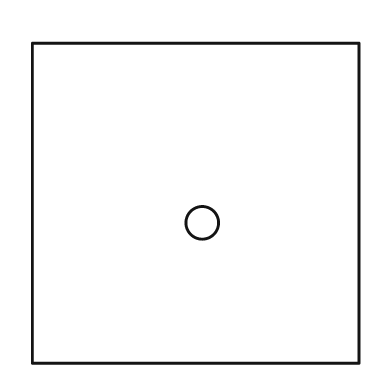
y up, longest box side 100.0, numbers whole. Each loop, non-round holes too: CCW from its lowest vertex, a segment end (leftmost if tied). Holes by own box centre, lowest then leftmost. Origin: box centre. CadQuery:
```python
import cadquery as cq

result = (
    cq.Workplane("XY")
    .moveTo(-50.0, -49.0)
    .lineTo(50.0, -49.0)
    .lineTo(50.0, 49.0)
    .lineTo(-50.0, 49.0)
    .close()
    .moveTo(2.0, -6.0)
    .circle(5.0)
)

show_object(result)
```